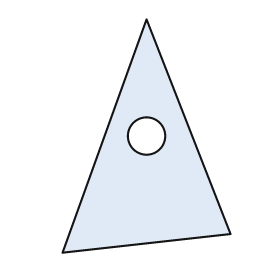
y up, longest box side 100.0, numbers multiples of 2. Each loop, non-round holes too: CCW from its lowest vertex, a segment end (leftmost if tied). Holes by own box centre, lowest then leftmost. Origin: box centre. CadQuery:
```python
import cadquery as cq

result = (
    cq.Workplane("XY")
    .moveTo(-36.0, -50.0)
    .lineTo(36.0, -42.0)
    .lineTo(0.0, 50.0)
    .close()
    .moveTo(0.0, 0.0)
    .circle(8.0)
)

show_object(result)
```